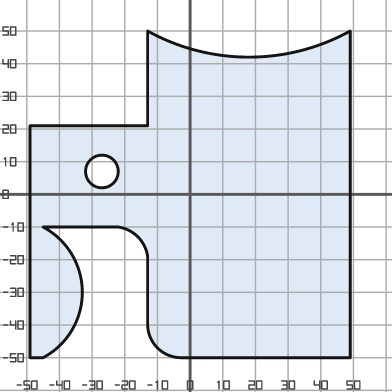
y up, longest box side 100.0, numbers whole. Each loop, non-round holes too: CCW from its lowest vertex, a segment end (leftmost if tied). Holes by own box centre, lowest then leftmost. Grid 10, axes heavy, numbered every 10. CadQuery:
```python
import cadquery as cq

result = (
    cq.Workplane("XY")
    .moveTo(-49.0, -50.0)
    .lineTo(-45.0, -50.0)
    .threePointArc((-33.0, -30.0), (-45.0, -10.0))
    .lineTo(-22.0, -10.0)
    .threePointArc((-16.0, -13.0), (-13.0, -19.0))
    .lineTo(-13.0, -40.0)
    .threePointArc((-10.0, -47.0), (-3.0, -50.0))
    .lineTo(49.0, -50.0)
    .lineTo(49.0, 50.0)
    .threePointArc((18.0, 42.0), (-13.0, 50.0))
    .lineTo(-13.0, 21.0)
    .lineTo(-49.0, 21.0)
    .close()
    .moveTo(-27.0, 7.0)
    .circle(5.0)
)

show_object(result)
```